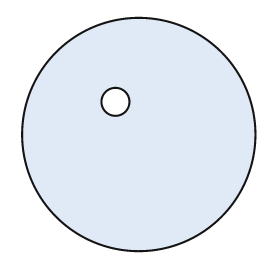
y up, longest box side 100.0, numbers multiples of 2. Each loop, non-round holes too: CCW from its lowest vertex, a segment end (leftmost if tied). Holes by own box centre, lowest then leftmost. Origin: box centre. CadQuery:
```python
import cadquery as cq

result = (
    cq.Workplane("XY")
    .moveTo(0.0, 0.0)
    .circle(50.0)
    .moveTo(-10.0, 14.0)
    .circle(6.0)
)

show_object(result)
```